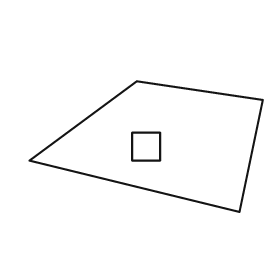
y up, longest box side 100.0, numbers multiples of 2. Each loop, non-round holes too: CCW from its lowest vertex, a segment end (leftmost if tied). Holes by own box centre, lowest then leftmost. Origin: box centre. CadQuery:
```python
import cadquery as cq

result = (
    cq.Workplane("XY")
    .moveTo(40.0, -28.0)
    .lineTo(50.0, 20.0)
    .lineTo(-4.0, 28.0)
    .lineTo(-50.0, -6.0)
    .close()
    .moveTo(-6.0, -6.0)
    .lineTo(6.0, -6.0)
    .lineTo(6.0, 6.0)
    .lineTo(-6.0, 6.0)
    .close()
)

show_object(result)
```